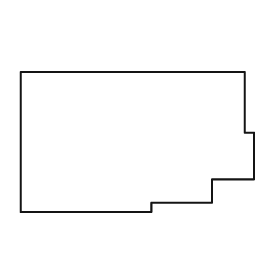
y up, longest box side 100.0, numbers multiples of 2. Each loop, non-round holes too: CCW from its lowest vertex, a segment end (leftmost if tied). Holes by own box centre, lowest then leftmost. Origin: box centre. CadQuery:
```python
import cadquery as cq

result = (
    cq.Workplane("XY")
    .moveTo(-50.0, -30.0)
    .lineTo(6.0, -30.0)
    .lineTo(6.0, -26.0)
    .lineTo(32.0, -26.0)
    .lineTo(32.0, -16.0)
    .lineTo(50.0, -16.0)
    .lineTo(50.0, 4.0)
    .lineTo(46.0, 4.0)
    .lineTo(46.0, 30.0)
    .lineTo(-50.0, 30.0)
    .close()
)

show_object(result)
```